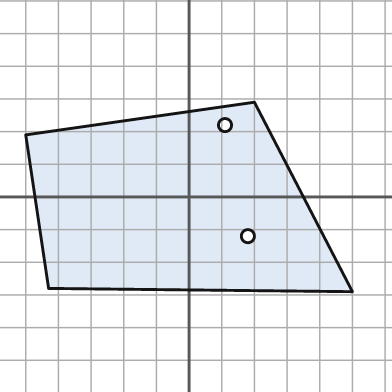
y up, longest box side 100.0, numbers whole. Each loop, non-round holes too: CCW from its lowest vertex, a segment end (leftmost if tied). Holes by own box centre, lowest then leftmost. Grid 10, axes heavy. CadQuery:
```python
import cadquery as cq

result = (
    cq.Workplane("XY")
    .moveTo(50.0, -29.0)
    .lineTo(20.0, 29.0)
    .lineTo(-50.0, 19.0)
    .lineTo(-43.0, -28.0)
    .close()
    .moveTo(18.0, -12.0)
    .circle(2.0)
    .moveTo(11.0, 22.0)
    .circle(2.0)
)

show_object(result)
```